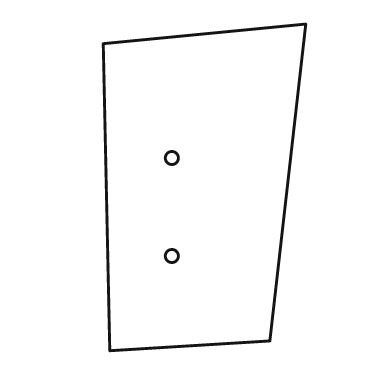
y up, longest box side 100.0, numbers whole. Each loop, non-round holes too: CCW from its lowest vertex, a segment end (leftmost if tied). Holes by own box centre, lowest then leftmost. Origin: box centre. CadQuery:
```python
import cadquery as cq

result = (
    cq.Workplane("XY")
    .moveTo(-29.0, -50.0)
    .lineTo(20.0, -47.0)
    .lineTo(31.0, 50.0)
    .lineTo(-31.0, 44.0)
    .close()
    .moveTo(-10.0, -21.0)
    .circle(2.0)
    .moveTo(-10.0, 9.0)
    .circle(2.0)
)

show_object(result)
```